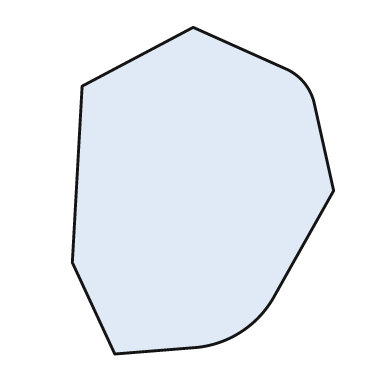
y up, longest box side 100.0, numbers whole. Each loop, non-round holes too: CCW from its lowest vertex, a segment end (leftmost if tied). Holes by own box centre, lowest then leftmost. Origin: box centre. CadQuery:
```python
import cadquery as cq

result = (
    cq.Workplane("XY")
    .moveTo(-27.0, -50.0)
    .lineTo(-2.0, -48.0)
    .threePointArc((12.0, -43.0), (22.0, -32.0))
    .lineTo(40.0, 0.0)
    .lineTo(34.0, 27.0)
    .threePointArc((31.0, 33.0), (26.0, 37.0))
    .lineTo(-3.0, 50.0)
    .lineTo(-37.0, 32.0)
    .lineTo(-40.0, -22.0)
    .close()
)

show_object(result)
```